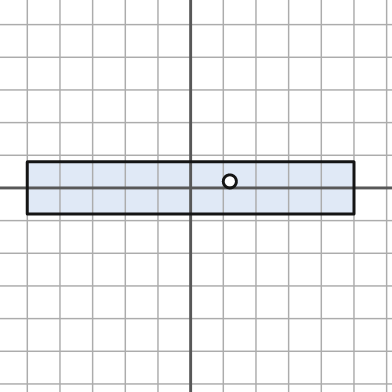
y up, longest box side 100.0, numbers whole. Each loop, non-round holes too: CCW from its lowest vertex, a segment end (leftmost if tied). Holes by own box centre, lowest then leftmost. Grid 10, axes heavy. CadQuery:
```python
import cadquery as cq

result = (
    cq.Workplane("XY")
    .moveTo(-50.0, -8.0)
    .lineTo(50.0, -8.0)
    .lineTo(50.0, 8.0)
    .lineTo(-50.0, 8.0)
    .close()
    .moveTo(12.0, 2.0)
    .circle(2.0)
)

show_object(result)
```